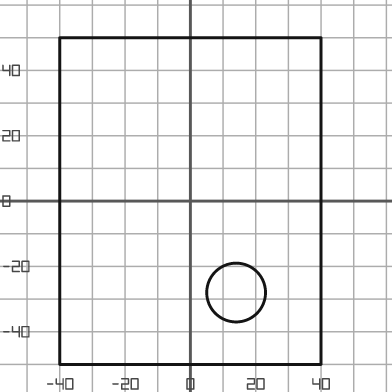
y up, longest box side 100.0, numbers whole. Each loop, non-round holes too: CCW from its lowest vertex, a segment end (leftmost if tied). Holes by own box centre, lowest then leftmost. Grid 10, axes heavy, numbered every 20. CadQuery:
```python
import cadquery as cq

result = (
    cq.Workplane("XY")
    .moveTo(-40.0, -50.0)
    .lineTo(40.0, -50.0)
    .lineTo(40.0, 50.0)
    .lineTo(-40.0, 50.0)
    .close()
    .moveTo(14.0, -28.0)
    .circle(9.0)
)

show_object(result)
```